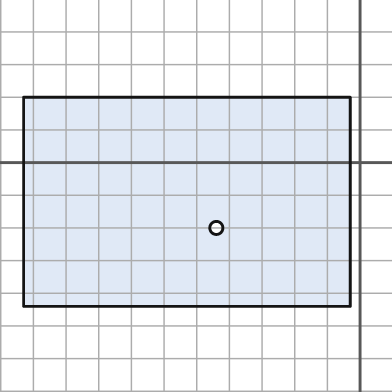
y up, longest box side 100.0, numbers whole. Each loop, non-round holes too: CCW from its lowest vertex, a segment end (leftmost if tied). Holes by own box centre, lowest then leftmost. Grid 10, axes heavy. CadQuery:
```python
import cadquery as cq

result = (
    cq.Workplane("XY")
    .moveTo(-103.0, -44.0)
    .lineTo(-3.0, -44.0)
    .lineTo(-3.0, 20.0)
    .lineTo(-103.0, 20.0)
    .close()
    .moveTo(-44.0, -20.0)
    .circle(2.0)
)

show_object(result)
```